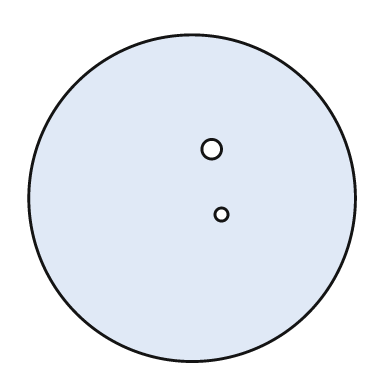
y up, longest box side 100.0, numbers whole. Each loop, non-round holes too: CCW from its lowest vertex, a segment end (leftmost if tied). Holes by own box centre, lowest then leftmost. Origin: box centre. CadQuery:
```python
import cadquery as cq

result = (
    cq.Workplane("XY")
    .moveTo(0.0, 0.0)
    .circle(50.0)
    .moveTo(9.0, -5.0)
    .circle(2.0)
    .moveTo(6.0, 15.0)
    .circle(3.0)
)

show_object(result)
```